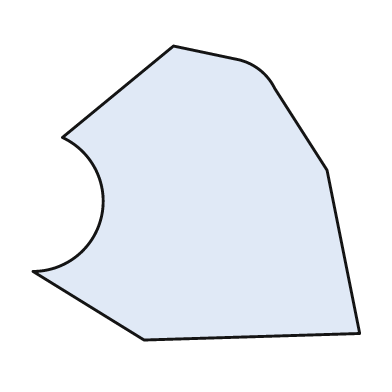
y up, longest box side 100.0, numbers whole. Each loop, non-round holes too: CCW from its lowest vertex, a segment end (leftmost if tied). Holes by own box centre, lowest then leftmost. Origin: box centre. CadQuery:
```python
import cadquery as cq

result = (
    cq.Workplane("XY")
    .moveTo(-16.0, -45.0)
    .lineTo(50.0, -43.0)
    .lineTo(40.0, 7.0)
    .lineTo(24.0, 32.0)
    .threePointArc((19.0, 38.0), (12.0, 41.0))
    .lineTo(-7.0, 45.0)
    .lineTo(-41.0, 17.0)
    .threePointArc((-29.0, -7.0), (-50.0, -24.0))
    .close()
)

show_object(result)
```